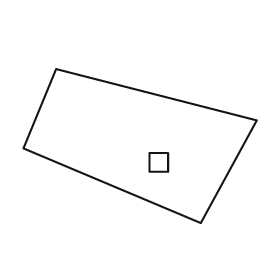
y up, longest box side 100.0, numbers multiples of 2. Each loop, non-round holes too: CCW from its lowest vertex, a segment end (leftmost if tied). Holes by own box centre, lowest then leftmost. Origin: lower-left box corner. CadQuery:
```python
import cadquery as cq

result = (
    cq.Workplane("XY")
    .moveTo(76.0, 0.0)
    .lineTo(100.0, 44.0)
    .lineTo(14.0, 66.0)
    .lineTo(0.0, 32.0)
    .close()
    .moveTo(54.0, 22.0)
    .lineTo(62.0, 22.0)
    .lineTo(62.0, 30.0)
    .lineTo(54.0, 30.0)
    .close()
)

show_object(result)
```